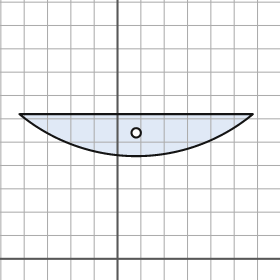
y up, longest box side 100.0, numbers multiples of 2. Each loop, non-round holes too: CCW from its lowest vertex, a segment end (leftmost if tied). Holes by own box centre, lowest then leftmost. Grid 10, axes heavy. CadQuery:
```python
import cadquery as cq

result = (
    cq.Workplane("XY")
    .moveTo(-42.0, 62.0)
    .threePointArc((8.0, 44.0), (58.0, 62.0))
    .close()
    .moveTo(8.0, 54.0)
    .circle(2.0)
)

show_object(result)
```